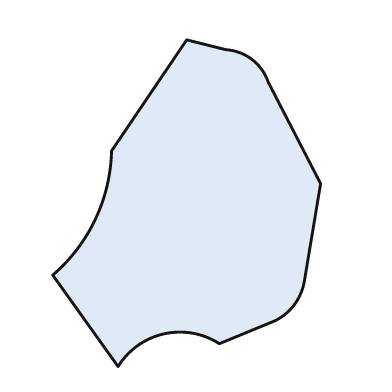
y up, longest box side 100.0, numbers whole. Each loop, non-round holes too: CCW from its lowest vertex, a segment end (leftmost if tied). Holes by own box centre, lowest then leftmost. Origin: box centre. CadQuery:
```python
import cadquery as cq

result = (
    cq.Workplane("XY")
    .moveTo(-21.0, -50.0)
    .threePointArc((-7.0, -40.0), (10.0, -43.0))
    .lineTo(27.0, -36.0)
    .threePointArc((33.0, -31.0), (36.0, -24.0))
    .lineTo(41.0, 6.0)
    .lineTo(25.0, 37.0)
    .threePointArc((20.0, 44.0), (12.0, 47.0))
    .lineTo(0.0, 50.0)
    .lineTo(-23.0, 16.0)
    .threePointArc((-28.0, -5.0), (-41.0, -22.0))
    .close()
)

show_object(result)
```